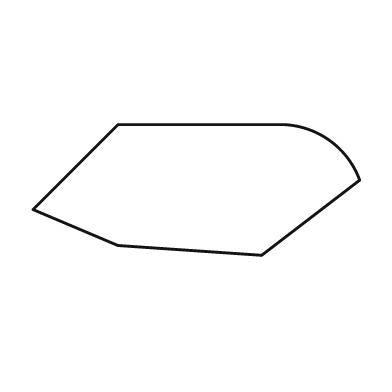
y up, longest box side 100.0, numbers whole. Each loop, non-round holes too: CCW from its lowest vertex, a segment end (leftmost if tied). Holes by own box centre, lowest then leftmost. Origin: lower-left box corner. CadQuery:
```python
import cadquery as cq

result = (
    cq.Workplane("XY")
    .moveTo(70.0, 0.0)
    .lineTo(100.0, 23.0)
    .threePointArc((91.0, 35.0), (77.0, 40.0))
    .lineTo(26.0, 40.0)
    .lineTo(0.0, 14.0)
    .lineTo(26.0, 3.0)
    .close()
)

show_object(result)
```